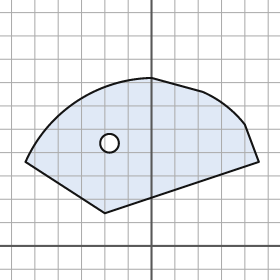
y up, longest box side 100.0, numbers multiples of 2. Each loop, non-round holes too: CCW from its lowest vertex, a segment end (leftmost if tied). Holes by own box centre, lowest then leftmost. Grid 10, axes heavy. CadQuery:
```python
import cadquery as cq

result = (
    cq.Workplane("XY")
    .moveTo(-20.0, 14.0)
    .lineTo(46.0, 36.0)
    .lineTo(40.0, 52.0)
    .threePointArc((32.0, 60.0), (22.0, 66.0))
    .lineTo(0.0, 72.0)
    .threePointArc((-32.0, 62.0), (-54.0, 36.0))
    .close()
    .moveTo(-18.0, 44.0)
    .circle(4.0)
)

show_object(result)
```